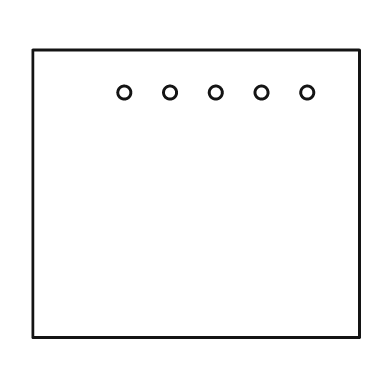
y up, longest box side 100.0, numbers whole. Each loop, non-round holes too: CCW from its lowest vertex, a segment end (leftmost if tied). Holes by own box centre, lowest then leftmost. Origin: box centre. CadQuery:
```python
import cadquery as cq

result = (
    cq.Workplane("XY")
    .moveTo(-50.0, -44.0)
    .lineTo(50.0, -44.0)
    .lineTo(50.0, 44.0)
    .lineTo(-50.0, 44.0)
    .close()
    .moveTo(-22.0, 31.0)
    .circle(2.0)
    .moveTo(-8.0, 31.0)
    .circle(2.0)
    .moveTo(6.0, 31.0)
    .circle(2.0)
    .moveTo(20.0, 31.0)
    .circle(2.0)
    .moveTo(34.0, 31.0)
    .circle(2.0)
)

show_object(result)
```